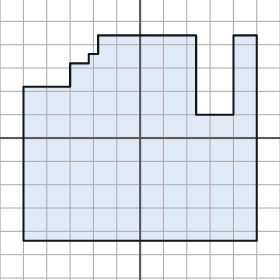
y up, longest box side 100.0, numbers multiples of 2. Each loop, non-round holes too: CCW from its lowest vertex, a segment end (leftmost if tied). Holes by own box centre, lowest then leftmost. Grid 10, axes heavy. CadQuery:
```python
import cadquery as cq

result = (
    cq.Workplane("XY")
    .moveTo(-50.0, -44.0)
    .lineTo(50.0, -44.0)
    .lineTo(50.0, 44.0)
    .lineTo(40.0, 44.0)
    .lineTo(40.0, 10.0)
    .lineTo(24.0, 10.0)
    .lineTo(24.0, 44.0)
    .lineTo(-18.0, 44.0)
    .lineTo(-18.0, 36.0)
    .lineTo(-22.0, 36.0)
    .lineTo(-22.0, 32.0)
    .lineTo(-30.0, 32.0)
    .lineTo(-30.0, 22.0)
    .lineTo(-50.0, 22.0)
    .close()
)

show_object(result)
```